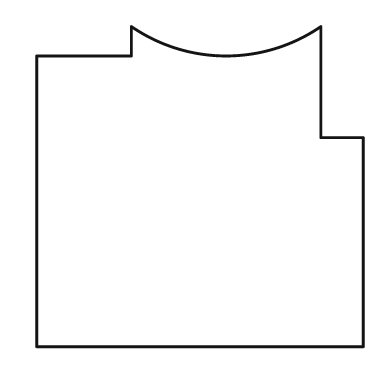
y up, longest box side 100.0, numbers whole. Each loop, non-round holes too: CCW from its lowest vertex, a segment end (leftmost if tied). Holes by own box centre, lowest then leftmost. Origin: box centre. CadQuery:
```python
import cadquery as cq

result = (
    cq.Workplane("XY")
    .moveTo(-50.0, -49.0)
    .lineTo(50.0, -49.0)
    .lineTo(50.0, 15.0)
    .lineTo(37.0, 15.0)
    .lineTo(37.0, 49.0)
    .threePointArc((8.0, 40.0), (-21.0, 49.0))
    .lineTo(-21.0, 40.0)
    .lineTo(-50.0, 40.0)
    .close()
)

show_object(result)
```